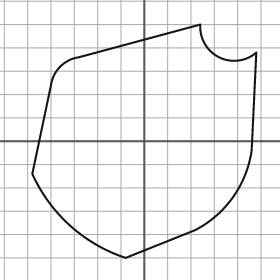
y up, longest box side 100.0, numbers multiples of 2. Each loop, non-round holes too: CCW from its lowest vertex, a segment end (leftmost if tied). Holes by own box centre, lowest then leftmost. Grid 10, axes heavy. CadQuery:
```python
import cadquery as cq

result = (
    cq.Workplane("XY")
    .moveTo(-8.0, -50.0)
    .lineTo(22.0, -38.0)
    .threePointArc((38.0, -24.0), (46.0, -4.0))
    .lineTo(48.0, 38.0)
    .threePointArc((32.0, 36.0), (24.0, 50.0))
    .lineTo(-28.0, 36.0)
    .threePointArc((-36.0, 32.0), (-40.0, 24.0))
    .lineTo(-48.0, -14.0)
    .threePointArc((-32.0, -36.0), (-8.0, -50.0))
    .close()
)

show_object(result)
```